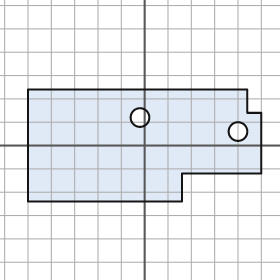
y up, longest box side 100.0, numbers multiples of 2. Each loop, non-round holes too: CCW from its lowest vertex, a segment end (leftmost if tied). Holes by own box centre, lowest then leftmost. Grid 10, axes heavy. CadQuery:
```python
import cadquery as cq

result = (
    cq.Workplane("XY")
    .moveTo(-50.0, -24.0)
    .lineTo(16.0, -24.0)
    .lineTo(16.0, -12.0)
    .lineTo(50.0, -12.0)
    .lineTo(50.0, 14.0)
    .lineTo(44.0, 14.0)
    .lineTo(44.0, 24.0)
    .lineTo(-50.0, 24.0)
    .close()
    .moveTo(40.0, 6.0)
    .circle(4.0)
    .moveTo(-2.0, 12.0)
    .circle(4.0)
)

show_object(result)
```